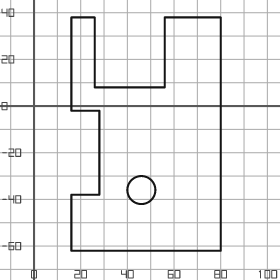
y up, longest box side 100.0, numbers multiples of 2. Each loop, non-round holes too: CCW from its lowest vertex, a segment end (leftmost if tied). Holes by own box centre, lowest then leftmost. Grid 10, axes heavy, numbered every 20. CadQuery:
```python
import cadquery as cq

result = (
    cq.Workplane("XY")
    .moveTo(16.0, -62.0)
    .lineTo(80.0, -62.0)
    .lineTo(80.0, 38.0)
    .lineTo(56.0, 38.0)
    .lineTo(56.0, 8.0)
    .lineTo(26.0, 8.0)
    .lineTo(26.0, 38.0)
    .lineTo(16.0, 38.0)
    .lineTo(16.0, -2.0)
    .lineTo(28.0, -2.0)
    .lineTo(28.0, -38.0)
    .lineTo(16.0, -38.0)
    .close()
    .moveTo(46.0, -36.0)
    .circle(6.0)
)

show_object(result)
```